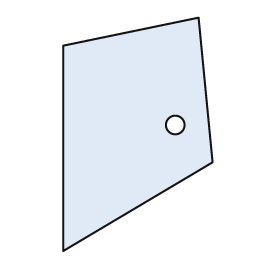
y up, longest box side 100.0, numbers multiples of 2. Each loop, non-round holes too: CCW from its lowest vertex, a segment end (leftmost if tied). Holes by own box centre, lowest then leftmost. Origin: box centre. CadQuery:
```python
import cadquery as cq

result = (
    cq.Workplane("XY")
    .moveTo(-32.0, -50.0)
    .lineTo(32.0, -12.0)
    .lineTo(26.0, 50.0)
    .lineTo(-32.0, 38.0)
    .close()
    .moveTo(16.0, 4.0)
    .circle(4.0)
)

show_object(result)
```